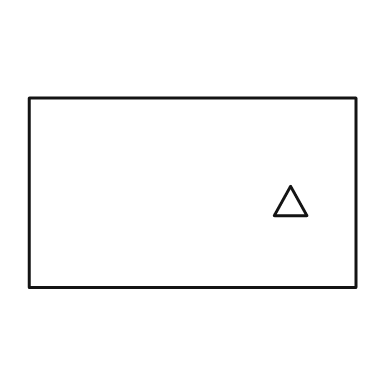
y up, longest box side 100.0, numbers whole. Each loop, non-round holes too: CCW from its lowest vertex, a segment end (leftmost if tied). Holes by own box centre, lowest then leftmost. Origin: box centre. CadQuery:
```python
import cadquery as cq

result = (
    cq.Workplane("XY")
    .moveTo(-50.0, -29.0)
    .lineTo(50.0, -29.0)
    .lineTo(50.0, 29.0)
    .lineTo(-50.0, 29.0)
    .close()
    .moveTo(25.0, -7.0)
    .lineTo(35.0, -7.0)
    .lineTo(30.0, 2.0)
    .close()
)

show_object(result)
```